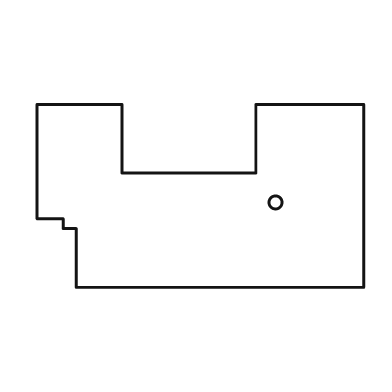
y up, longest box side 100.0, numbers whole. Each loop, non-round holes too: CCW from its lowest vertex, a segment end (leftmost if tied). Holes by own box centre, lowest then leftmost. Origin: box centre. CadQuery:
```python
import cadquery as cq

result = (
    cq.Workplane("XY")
    .moveTo(-38.0, -28.0)
    .lineTo(50.0, -28.0)
    .lineTo(50.0, 28.0)
    .lineTo(17.0, 28.0)
    .lineTo(17.0, 7.0)
    .lineTo(-24.0, 7.0)
    .lineTo(-24.0, 28.0)
    .lineTo(-50.0, 28.0)
    .lineTo(-50.0, -7.0)
    .lineTo(-42.0, -7.0)
    .lineTo(-42.0, -10.0)
    .lineTo(-38.0, -10.0)
    .close()
    .moveTo(23.0, -2.0)
    .circle(2.0)
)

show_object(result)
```